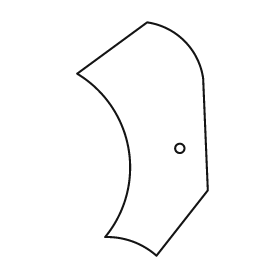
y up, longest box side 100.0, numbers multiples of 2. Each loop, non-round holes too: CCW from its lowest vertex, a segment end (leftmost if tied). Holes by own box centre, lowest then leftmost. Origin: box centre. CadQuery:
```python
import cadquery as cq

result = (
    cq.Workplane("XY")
    .moveTo(6.0, -50.0)
    .lineTo(28.0, -22.0)
    .lineTo(26.0, 26.0)
    .threePointArc((18.0, 42.0), (2.0, 50.0))
    .lineTo(-28.0, 28.0)
    .threePointArc((-6.0, -4.0), (-16.0, -42.0))
    .threePointArc((-4.0, -44.0), (6.0, -50.0))
    .close()
    .moveTo(16.0, -4.0)
    .circle(2.0)
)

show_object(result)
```